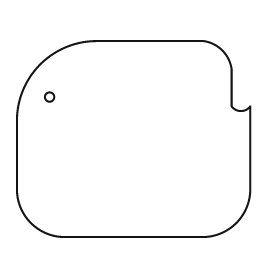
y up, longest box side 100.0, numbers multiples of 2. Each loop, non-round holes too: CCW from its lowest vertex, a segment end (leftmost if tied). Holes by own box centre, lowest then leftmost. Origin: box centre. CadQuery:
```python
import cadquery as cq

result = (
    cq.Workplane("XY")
    .moveTo(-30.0, -42.0)
    .lineTo(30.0, -42.0)
    .threePointArc((44.0, -36.0), (50.0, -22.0))
    .lineTo(50.0, 14.0)
    .threePointArc((46.0, 12.0), (42.0, 14.0))
    .lineTo(42.0, 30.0)
    .threePointArc((38.0, 38.0), (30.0, 42.0))
    .lineTo(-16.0, 42.0)
    .threePointArc((-40.0, 32.0), (-50.0, 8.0))
    .lineTo(-50.0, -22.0)
    .threePointArc((-44.0, -36.0), (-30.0, -42.0))
    .close()
    .moveTo(-36.0, 18.0)
    .circle(2.0)
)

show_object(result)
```